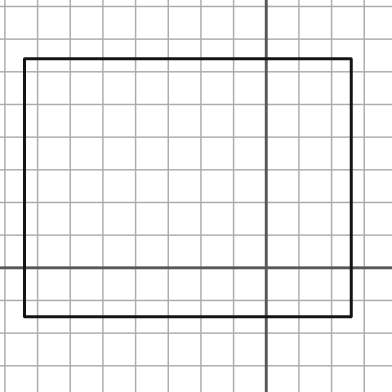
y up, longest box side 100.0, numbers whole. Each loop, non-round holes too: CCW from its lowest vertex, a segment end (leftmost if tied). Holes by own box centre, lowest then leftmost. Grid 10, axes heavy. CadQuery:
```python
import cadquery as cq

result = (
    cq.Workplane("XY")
    .moveTo(-74.0, -15.0)
    .lineTo(26.0, -15.0)
    .lineTo(26.0, 64.0)
    .lineTo(-74.0, 64.0)
    .close()
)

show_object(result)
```